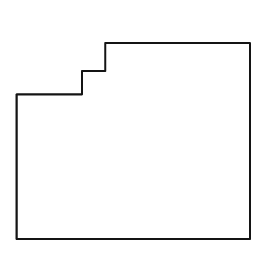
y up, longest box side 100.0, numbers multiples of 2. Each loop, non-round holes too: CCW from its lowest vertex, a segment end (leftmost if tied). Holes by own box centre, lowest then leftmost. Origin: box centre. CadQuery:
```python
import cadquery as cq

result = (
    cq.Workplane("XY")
    .moveTo(-50.0, -42.0)
    .lineTo(50.0, -42.0)
    .lineTo(50.0, 42.0)
    .lineTo(-12.0, 42.0)
    .lineTo(-12.0, 30.0)
    .lineTo(-22.0, 30.0)
    .lineTo(-22.0, 20.0)
    .lineTo(-50.0, 20.0)
    .close()
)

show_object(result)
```